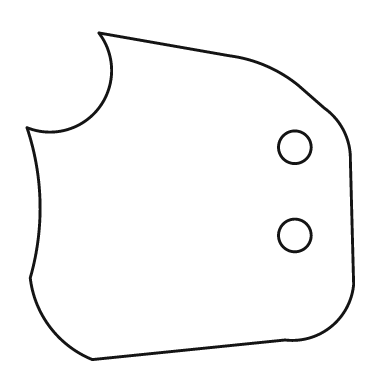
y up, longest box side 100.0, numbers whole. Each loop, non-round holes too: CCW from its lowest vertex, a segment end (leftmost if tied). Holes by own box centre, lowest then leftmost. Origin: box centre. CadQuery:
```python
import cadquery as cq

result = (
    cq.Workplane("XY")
    .moveTo(-30.0, -50.0)
    .lineTo(29.0, -44.0)
    .threePointArc((43.0, -40.0), (50.0, -27.0))
    .lineTo(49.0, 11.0)
    .threePointArc((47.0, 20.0), (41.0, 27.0))
    .lineTo(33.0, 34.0)
    .threePointArc((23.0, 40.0), (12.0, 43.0))
    .lineTo(-28.0, 50.0)
    .threePointArc((-28.0, 27.0), (-50.0, 21.0))
    .threePointArc((-46.0, -2.0), (-49.0, -25.0))
    .threePointArc((-43.0, -40.0), (-30.0, -50.0))
    .close()
    .moveTo(32.0, -12.0)
    .circle(5.0)
    .moveTo(32.0, 15.0)
    .circle(5.0)
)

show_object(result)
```